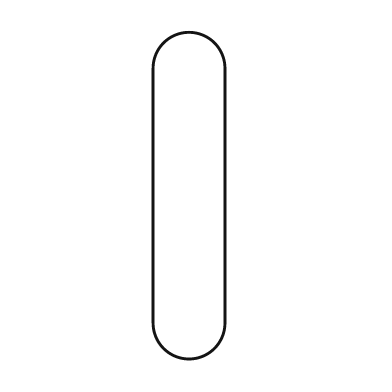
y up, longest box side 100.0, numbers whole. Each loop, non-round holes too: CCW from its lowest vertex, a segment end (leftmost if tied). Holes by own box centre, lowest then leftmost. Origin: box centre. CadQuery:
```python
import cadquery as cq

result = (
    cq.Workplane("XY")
    .moveTo(-11.0, -39.0)
    .threePointArc((0.0, -50.0), (11.0, -39.0))
    .lineTo(11.0, 39.0)
    .threePointArc((0.0, 50.0), (-11.0, 39.0))
    .close()
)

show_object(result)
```